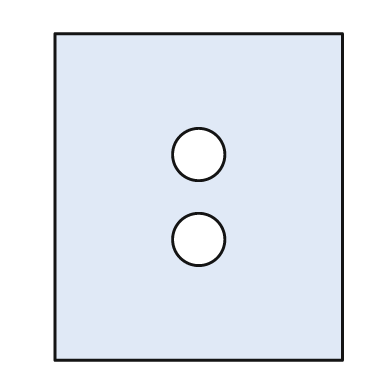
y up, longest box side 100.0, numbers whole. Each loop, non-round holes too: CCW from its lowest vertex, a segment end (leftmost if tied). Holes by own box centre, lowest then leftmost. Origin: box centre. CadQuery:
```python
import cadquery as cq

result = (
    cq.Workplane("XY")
    .moveTo(-44.0, -50.0)
    .lineTo(44.0, -50.0)
    .lineTo(44.0, 50.0)
    .lineTo(-44.0, 50.0)
    .close()
    .moveTo(0.0, -13.0)
    .circle(8.0)
    .moveTo(0.0, 13.0)
    .circle(8.0)
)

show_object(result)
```